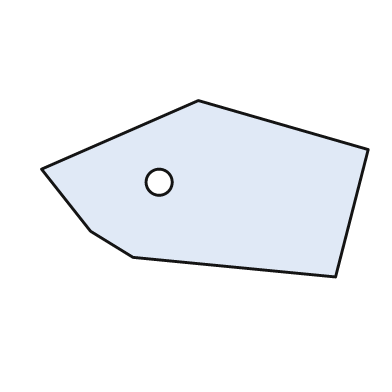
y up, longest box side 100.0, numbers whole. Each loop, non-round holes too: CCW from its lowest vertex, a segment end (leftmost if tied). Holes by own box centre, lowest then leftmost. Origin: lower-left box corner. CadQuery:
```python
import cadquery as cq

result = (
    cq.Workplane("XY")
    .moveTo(90.0, 0.0)
    .lineTo(100.0, 39.0)
    .lineTo(48.0, 54.0)
    .lineTo(0.0, 33.0)
    .lineTo(15.0, 14.0)
    .lineTo(28.0, 6.0)
    .close()
    .moveTo(36.0, 29.0)
    .circle(4.0)
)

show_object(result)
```